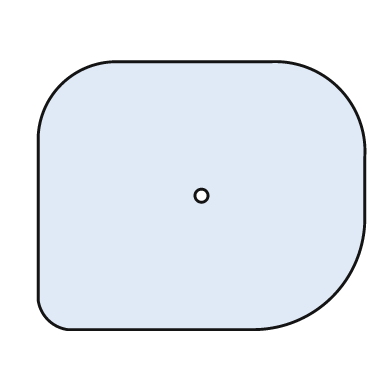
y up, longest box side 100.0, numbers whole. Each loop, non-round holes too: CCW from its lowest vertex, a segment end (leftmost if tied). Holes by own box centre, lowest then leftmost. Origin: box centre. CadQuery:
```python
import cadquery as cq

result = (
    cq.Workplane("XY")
    .moveTo(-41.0, -41.0)
    .lineTo(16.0, -41.0)
    .threePointArc((40.0, -31.0), (50.0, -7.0))
    .lineTo(50.0, 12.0)
    .threePointArc((42.0, 33.0), (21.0, 41.0))
    .lineTo(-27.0, 41.0)
    .threePointArc((-43.0, 34.0), (-50.0, 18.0))
    .lineTo(-50.0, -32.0)
    .threePointArc((-47.0, -38.0), (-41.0, -41.0))
    .close()
    .moveTo(0.0, 0.0)
    .circle(2.0)
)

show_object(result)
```